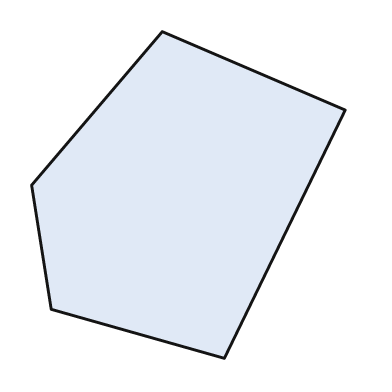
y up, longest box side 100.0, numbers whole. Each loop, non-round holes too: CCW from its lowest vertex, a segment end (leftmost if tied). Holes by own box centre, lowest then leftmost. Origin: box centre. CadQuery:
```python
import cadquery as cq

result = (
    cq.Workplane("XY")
    .moveTo(11.0, -50.0)
    .lineTo(48.0, 26.0)
    .lineTo(-8.0, 50.0)
    .lineTo(-48.0, 3.0)
    .lineTo(-42.0, -35.0)
    .close()
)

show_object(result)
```